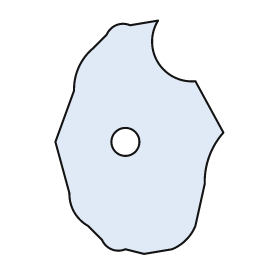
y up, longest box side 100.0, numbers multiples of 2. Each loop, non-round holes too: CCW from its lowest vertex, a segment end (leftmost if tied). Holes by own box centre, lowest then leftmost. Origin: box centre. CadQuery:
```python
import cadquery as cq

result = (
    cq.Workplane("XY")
    .moveTo(2.0, -50.0)
    .lineTo(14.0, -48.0)
    .threePointArc((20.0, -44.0), (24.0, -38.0))
    .lineTo(28.0, -20.0)
    .threePointArc((30.0, -8.0), (36.0, 2.0))
    .lineTo(24.0, 24.0)
    .threePointArc((8.0, 32.0), (8.0, 50.0))
    .lineTo(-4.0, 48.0)
    .threePointArc((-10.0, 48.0), (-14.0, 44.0))
    .lineTo(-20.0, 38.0)
    .threePointArc((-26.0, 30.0), (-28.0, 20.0))
    .lineTo(-36.0, -2.0)
    .lineTo(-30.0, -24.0)
    .threePointArc((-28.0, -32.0), (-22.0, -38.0))
    .lineTo(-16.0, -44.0)
    .threePointArc((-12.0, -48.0), (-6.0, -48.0))
    .close()
    .moveTo(-6.0, -2.0)
    .circle(6.0)
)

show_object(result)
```